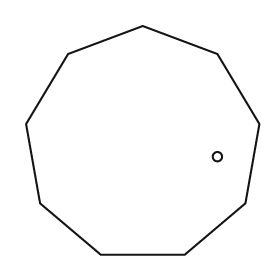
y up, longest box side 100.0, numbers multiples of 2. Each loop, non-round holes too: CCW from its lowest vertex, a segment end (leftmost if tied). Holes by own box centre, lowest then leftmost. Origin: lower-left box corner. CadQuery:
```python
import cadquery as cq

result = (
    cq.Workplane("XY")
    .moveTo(32.0, 0.0)
    .lineTo(68.0, 0.0)
    .lineTo(94.0, 22.0)
    .lineTo(100.0, 56.0)
    .lineTo(82.0, 86.0)
    .lineTo(50.0, 98.0)
    .lineTo(18.0, 86.0)
    .lineTo(0.0, 56.0)
    .lineTo(6.0, 22.0)
    .close()
    .moveTo(82.0, 42.0)
    .circle(2.0)
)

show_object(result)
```